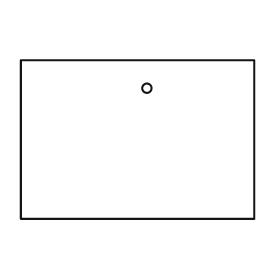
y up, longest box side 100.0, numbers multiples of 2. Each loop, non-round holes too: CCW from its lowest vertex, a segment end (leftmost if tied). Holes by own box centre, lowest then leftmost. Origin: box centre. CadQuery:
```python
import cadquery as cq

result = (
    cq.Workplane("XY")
    .moveTo(-50.0, -34.0)
    .lineTo(50.0, -34.0)
    .lineTo(50.0, 34.0)
    .lineTo(-50.0, 34.0)
    .close()
    .moveTo(4.0, 22.0)
    .circle(2.0)
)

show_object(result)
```